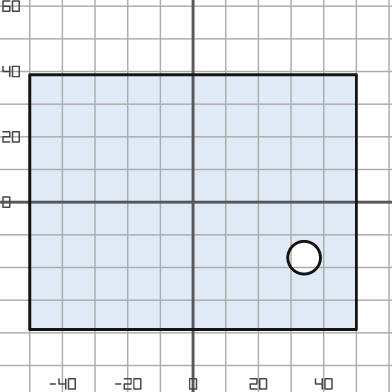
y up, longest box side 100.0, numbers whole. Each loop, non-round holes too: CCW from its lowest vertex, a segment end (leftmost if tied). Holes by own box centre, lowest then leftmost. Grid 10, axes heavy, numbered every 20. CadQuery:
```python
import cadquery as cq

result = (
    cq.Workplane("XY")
    .moveTo(-50.0, -39.0)
    .lineTo(50.0, -39.0)
    .lineTo(50.0, 39.0)
    .lineTo(-50.0, 39.0)
    .close()
    .moveTo(34.0, -17.0)
    .circle(5.0)
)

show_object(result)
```